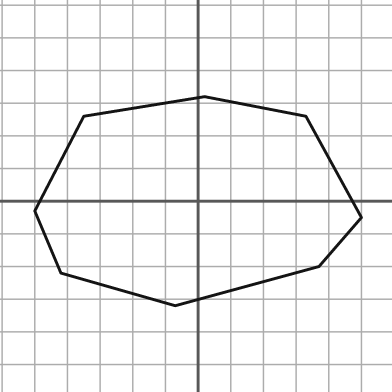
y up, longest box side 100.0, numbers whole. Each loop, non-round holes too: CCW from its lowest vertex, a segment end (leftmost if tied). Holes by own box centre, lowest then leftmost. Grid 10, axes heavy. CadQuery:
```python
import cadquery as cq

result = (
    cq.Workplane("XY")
    .moveTo(-7.0, -32.0)
    .lineTo(37.0, -20.0)
    .lineTo(50.0, -5.0)
    .lineTo(33.0, 26.0)
    .lineTo(2.0, 32.0)
    .lineTo(-35.0, 26.0)
    .lineTo(-50.0, -3.0)
    .lineTo(-42.0, -22.0)
    .close()
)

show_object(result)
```